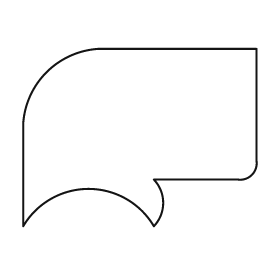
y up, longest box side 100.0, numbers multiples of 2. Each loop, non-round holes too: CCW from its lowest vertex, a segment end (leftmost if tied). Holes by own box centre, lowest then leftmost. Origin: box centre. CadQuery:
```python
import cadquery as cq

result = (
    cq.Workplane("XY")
    .moveTo(-50.0, -38.0)
    .threePointArc((-22.0, -22.0), (6.0, -38.0))
    .threePointArc((10.0, -28.0), (6.0, -18.0))
    .lineTo(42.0, -18.0)
    .threePointArc((48.0, -16.0), (50.0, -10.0))
    .lineTo(50.0, 38.0)
    .lineTo(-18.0, 38.0)
    .threePointArc((-40.0, 28.0), (-50.0, 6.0))
    .close()
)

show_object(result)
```